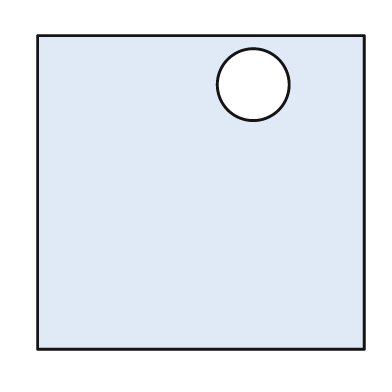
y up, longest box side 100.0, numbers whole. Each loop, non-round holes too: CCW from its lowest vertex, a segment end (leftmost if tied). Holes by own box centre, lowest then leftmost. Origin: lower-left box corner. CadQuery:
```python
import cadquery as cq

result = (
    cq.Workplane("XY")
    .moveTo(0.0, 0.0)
    .lineTo(100.0, 0.0)
    .lineTo(100.0, 96.0)
    .lineTo(0.0, 96.0)
    .close()
    .moveTo(66.0, 81.0)
    .circle(11.0)
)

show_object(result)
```